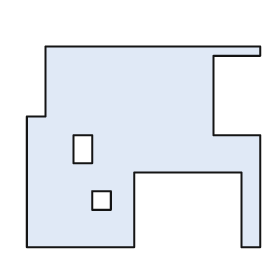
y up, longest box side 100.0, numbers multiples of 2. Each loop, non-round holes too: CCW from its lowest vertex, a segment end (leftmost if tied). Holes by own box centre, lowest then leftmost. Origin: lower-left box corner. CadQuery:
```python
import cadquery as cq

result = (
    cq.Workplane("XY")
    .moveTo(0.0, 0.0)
    .lineTo(46.0, 0.0)
    .lineTo(46.0, 32.0)
    .lineTo(92.0, 32.0)
    .lineTo(92.0, 0.0)
    .lineTo(100.0, 0.0)
    .lineTo(100.0, 48.0)
    .lineTo(80.0, 48.0)
    .lineTo(80.0, 82.0)
    .lineTo(100.0, 82.0)
    .lineTo(100.0, 86.0)
    .lineTo(8.0, 86.0)
    .lineTo(8.0, 56.0)
    .lineTo(0.0, 56.0)
    .close()
    .moveTo(28.0, 16.0)
    .lineTo(36.0, 16.0)
    .lineTo(36.0, 24.0)
    .lineTo(28.0, 24.0)
    .close()
    .moveTo(20.0, 36.0)
    .lineTo(28.0, 36.0)
    .lineTo(28.0, 48.0)
    .lineTo(20.0, 48.0)
    .close()
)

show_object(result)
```